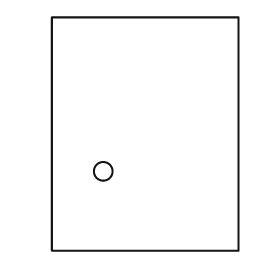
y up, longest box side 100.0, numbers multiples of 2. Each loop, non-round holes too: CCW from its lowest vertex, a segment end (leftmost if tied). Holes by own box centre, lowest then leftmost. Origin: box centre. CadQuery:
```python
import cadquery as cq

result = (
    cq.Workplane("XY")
    .moveTo(-40.0, -50.0)
    .lineTo(40.0, -50.0)
    .lineTo(40.0, 50.0)
    .lineTo(-40.0, 50.0)
    .close()
    .moveTo(-18.0, -16.0)
    .circle(4.0)
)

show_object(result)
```